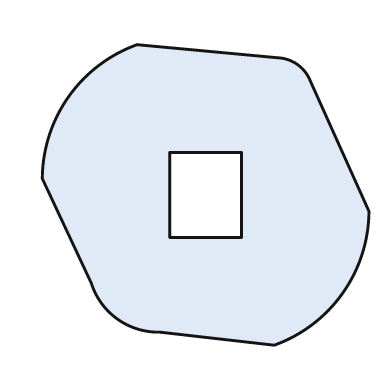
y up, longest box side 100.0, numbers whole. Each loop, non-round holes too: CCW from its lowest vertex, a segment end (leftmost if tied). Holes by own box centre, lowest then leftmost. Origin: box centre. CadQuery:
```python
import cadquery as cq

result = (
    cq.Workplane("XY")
    .moveTo(21.0, -46.0)
    .threePointArc((42.0, -30.0), (50.0, -5.0))
    .lineTo(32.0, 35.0)
    .threePointArc((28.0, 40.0), (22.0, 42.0))
    .lineTo(-21.0, 46.0)
    .threePointArc((-42.0, 30.0), (-50.0, 5.0))
    .lineTo(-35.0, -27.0)
    .threePointArc((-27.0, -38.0), (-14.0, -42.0))
    .close()
    .moveTo(-11.0, -13.0)
    .lineTo(11.0, -13.0)
    .lineTo(11.0, 13.0)
    .lineTo(-11.0, 13.0)
    .close()
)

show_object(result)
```